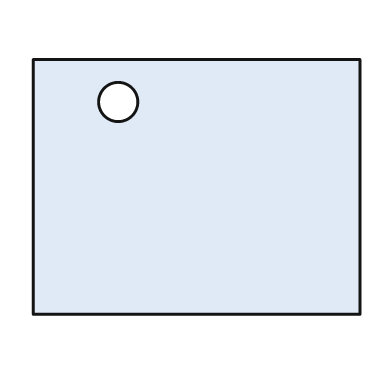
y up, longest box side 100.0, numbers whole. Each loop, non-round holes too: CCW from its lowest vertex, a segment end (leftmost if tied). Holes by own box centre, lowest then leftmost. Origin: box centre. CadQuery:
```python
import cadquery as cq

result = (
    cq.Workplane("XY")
    .moveTo(-50.0, -39.0)
    .lineTo(50.0, -39.0)
    .lineTo(50.0, 39.0)
    .lineTo(-50.0, 39.0)
    .close()
    .moveTo(-24.0, 26.0)
    .circle(6.0)
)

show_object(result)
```